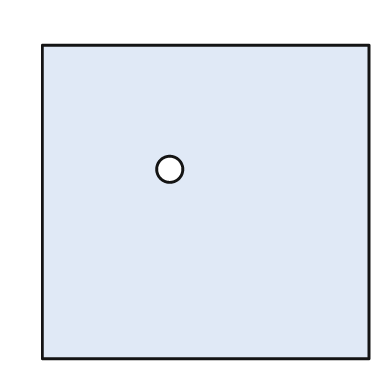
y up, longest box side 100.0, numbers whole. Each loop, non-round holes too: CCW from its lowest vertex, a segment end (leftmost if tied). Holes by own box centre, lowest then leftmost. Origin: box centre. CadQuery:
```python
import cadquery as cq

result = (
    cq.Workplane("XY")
    .moveTo(-50.0, -48.0)
    .lineTo(50.0, -48.0)
    .lineTo(50.0, 48.0)
    .lineTo(-50.0, 48.0)
    .close()
    .moveTo(-11.0, 10.0)
    .circle(4.0)
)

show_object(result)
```